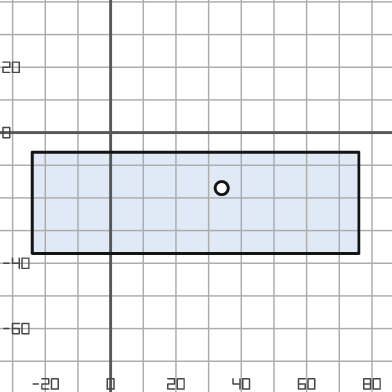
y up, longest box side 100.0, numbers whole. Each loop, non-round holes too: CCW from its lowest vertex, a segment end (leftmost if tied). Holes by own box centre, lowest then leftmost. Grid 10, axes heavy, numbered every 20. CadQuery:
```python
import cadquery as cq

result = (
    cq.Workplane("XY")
    .moveTo(-24.0, -37.0)
    .lineTo(76.0, -37.0)
    .lineTo(76.0, -6.0)
    .lineTo(-24.0, -6.0)
    .close()
    .moveTo(34.0, -17.0)
    .circle(2.0)
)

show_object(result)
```